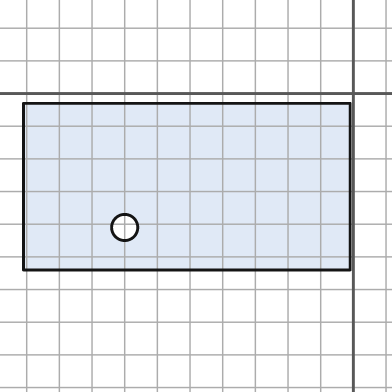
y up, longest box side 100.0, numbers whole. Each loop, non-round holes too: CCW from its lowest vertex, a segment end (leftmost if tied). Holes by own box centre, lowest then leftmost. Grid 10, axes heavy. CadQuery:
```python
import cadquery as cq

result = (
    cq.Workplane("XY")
    .moveTo(-101.0, -54.0)
    .lineTo(-1.0, -54.0)
    .lineTo(-1.0, -3.0)
    .lineTo(-101.0, -3.0)
    .close()
    .moveTo(-70.0, -41.0)
    .circle(4.0)
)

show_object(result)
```